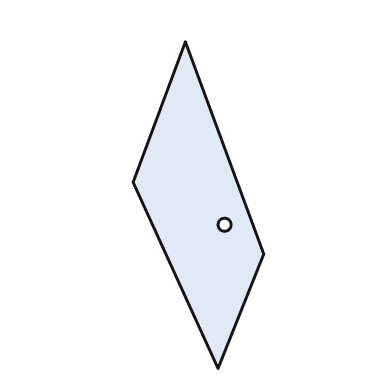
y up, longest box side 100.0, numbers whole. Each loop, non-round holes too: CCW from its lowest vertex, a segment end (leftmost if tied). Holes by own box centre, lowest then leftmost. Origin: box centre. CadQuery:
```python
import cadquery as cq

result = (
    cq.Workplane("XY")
    .moveTo(6.0, -50.0)
    .lineTo(20.0, -15.0)
    .lineTo(-4.0, 50.0)
    .lineTo(-20.0, 7.0)
    .close()
    .moveTo(8.0, -6.0)
    .circle(2.0)
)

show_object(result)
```